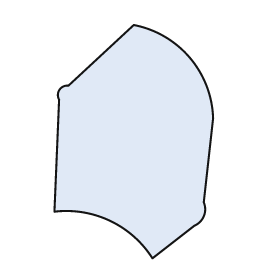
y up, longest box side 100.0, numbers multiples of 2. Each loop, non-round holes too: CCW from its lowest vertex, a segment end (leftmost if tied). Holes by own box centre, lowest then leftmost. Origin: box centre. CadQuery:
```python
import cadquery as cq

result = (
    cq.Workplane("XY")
    .moveTo(8.0, -50.0)
    .lineTo(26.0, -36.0)
    .threePointArc((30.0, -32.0), (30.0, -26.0))
    .lineTo(34.0, 10.0)
    .threePointArc((24.0, 36.0), (0.0, 50.0))
    .lineTo(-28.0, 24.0)
    .threePointArc((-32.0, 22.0), (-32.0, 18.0))
    .lineTo(-34.0, -30.0)
    .threePointArc((-10.0, -34.0), (8.0, -50.0))
    .close()
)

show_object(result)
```